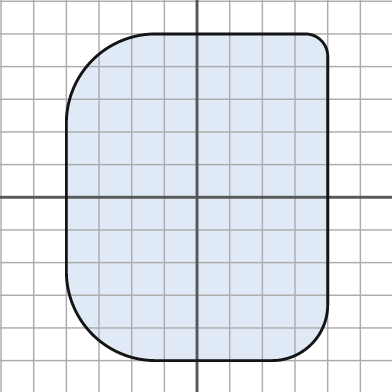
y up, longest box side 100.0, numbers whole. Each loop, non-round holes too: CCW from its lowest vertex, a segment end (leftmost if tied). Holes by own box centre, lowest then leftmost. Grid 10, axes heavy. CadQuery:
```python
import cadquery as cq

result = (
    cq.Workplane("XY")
    .moveTo(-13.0, -50.0)
    .lineTo(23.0, -50.0)
    .threePointArc((35.0, -45.0), (40.0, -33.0))
    .lineTo(40.0, 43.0)
    .threePointArc((38.0, 48.0), (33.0, 50.0))
    .lineTo(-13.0, 50.0)
    .threePointArc((-32.0, 42.0), (-40.0, 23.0))
    .lineTo(-40.0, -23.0)
    .threePointArc((-32.0, -42.0), (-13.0, -50.0))
    .close()
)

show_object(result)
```